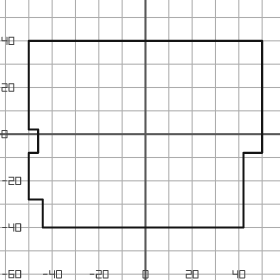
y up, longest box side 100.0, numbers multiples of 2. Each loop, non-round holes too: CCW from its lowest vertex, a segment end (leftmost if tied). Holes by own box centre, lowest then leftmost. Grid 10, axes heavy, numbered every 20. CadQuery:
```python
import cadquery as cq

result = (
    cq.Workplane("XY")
    .moveTo(-44.0, -40.0)
    .lineTo(42.0, -40.0)
    .lineTo(42.0, -8.0)
    .lineTo(50.0, -8.0)
    .lineTo(50.0, 40.0)
    .lineTo(-50.0, 40.0)
    .lineTo(-50.0, 2.0)
    .lineTo(-46.0, 2.0)
    .lineTo(-46.0, -8.0)
    .lineTo(-50.0, -8.0)
    .lineTo(-50.0, -28.0)
    .lineTo(-44.0, -28.0)
    .close()
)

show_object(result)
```